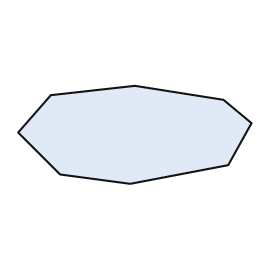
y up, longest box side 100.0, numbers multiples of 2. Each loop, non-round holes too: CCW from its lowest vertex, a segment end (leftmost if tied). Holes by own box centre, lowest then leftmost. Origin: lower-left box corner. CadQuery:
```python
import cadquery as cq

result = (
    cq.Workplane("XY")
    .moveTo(48.0, 0.0)
    .lineTo(90.0, 8.0)
    .lineTo(100.0, 26.0)
    .lineTo(88.0, 36.0)
    .lineTo(50.0, 42.0)
    .lineTo(14.0, 38.0)
    .lineTo(0.0, 22.0)
    .lineTo(18.0, 4.0)
    .close()
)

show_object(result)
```